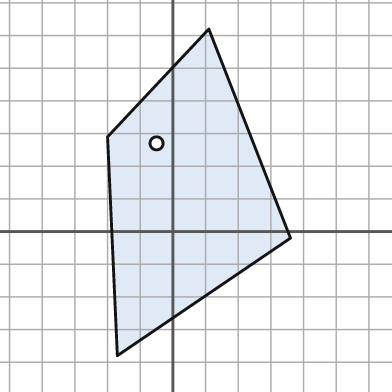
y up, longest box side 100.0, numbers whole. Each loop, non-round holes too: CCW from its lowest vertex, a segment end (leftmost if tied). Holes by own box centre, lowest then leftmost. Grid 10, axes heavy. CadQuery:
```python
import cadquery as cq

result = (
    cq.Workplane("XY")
    .moveTo(-17.0, -38.0)
    .lineTo(36.0, -2.0)
    .lineTo(11.0, 62.0)
    .lineTo(-20.0, 29.0)
    .close()
    .moveTo(-5.0, 27.0)
    .circle(2.0)
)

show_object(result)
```